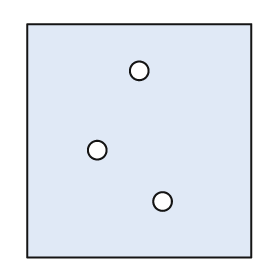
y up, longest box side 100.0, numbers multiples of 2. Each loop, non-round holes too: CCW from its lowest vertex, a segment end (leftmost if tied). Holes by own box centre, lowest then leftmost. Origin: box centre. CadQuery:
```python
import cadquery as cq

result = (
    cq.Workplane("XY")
    .moveTo(-48.0, -50.0)
    .lineTo(48.0, -50.0)
    .lineTo(48.0, 50.0)
    .lineTo(-48.0, 50.0)
    .close()
    .moveTo(10.0, -26.0)
    .circle(4.0)
    .moveTo(-18.0, -4.0)
    .circle(4.0)
    .moveTo(0.0, 30.0)
    .circle(4.0)
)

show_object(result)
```